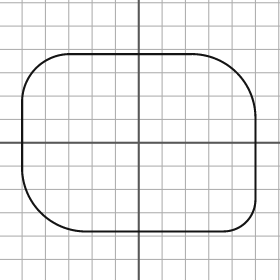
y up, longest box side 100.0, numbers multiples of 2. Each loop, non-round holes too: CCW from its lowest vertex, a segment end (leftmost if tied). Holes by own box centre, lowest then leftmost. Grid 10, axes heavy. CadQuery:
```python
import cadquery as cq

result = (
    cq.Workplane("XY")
    .moveTo(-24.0, -38.0)
    .lineTo(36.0, -38.0)
    .threePointArc((46.0, -34.0), (50.0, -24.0))
    .lineTo(50.0, 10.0)
    .threePointArc((42.0, 30.0), (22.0, 38.0))
    .lineTo(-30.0, 38.0)
    .threePointArc((-44.0, 32.0), (-50.0, 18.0))
    .lineTo(-50.0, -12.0)
    .threePointArc((-42.0, -30.0), (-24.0, -38.0))
    .close()
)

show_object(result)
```